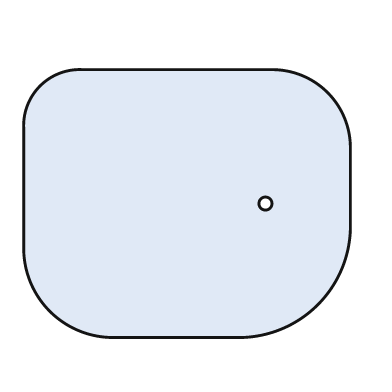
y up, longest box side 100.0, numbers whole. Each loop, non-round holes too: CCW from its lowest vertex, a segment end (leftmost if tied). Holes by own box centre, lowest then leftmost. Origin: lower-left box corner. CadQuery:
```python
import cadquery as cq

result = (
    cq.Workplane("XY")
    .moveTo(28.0, 0.0)
    .lineTo(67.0, 0.0)
    .threePointArc((90.0, 10.0), (100.0, 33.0))
    .lineTo(100.0, 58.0)
    .threePointArc((93.0, 75.0), (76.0, 82.0))
    .lineTo(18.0, 82.0)
    .threePointArc((5.0, 77.0), (0.0, 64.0))
    .lineTo(0.0, 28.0)
    .threePointArc((8.0, 8.0), (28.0, 0.0))
    .close()
    .moveTo(74.0, 41.0)
    .circle(2.0)
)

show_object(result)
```